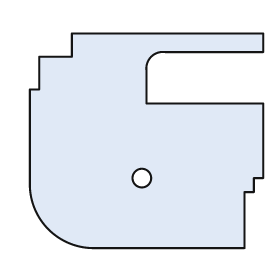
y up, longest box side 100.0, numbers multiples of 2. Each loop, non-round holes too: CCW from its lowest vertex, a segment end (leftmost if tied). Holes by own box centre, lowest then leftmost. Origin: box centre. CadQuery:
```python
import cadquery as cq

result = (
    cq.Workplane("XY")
    .moveTo(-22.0, -46.0)
    .lineTo(42.0, -46.0)
    .lineTo(42.0, -22.0)
    .lineTo(46.0, -22.0)
    .lineTo(46.0, -16.0)
    .lineTo(50.0, -16.0)
    .lineTo(50.0, 16.0)
    .lineTo(0.0, 16.0)
    .lineTo(0.0, 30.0)
    .threePointArc((2.0, 36.0), (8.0, 38.0))
    .lineTo(50.0, 38.0)
    .lineTo(50.0, 46.0)
    .lineTo(-32.0, 46.0)
    .lineTo(-32.0, 36.0)
    .lineTo(-46.0, 36.0)
    .lineTo(-46.0, 22.0)
    .lineTo(-50.0, 22.0)
    .lineTo(-50.0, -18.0)
    .threePointArc((-42.0, -38.0), (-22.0, -46.0))
    .close()
    .moveTo(-2.0, -16.0)
    .circle(4.0)
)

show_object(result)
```